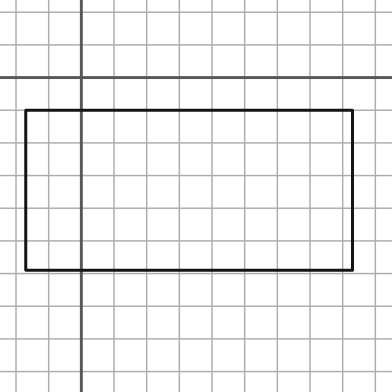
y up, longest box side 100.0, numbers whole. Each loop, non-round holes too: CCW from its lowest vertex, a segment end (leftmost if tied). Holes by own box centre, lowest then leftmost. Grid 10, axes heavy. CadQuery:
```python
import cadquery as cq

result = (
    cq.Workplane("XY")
    .moveTo(-17.0, -59.0)
    .lineTo(83.0, -59.0)
    .lineTo(83.0, -10.0)
    .lineTo(-17.0, -10.0)
    .close()
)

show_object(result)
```